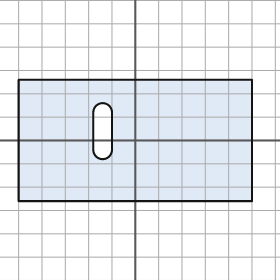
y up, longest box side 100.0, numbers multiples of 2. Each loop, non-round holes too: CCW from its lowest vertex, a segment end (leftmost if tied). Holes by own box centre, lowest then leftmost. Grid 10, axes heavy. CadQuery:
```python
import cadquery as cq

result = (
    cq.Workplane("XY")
    .moveTo(-50.0, -26.0)
    .lineTo(50.0, -26.0)
    .lineTo(50.0, 26.0)
    .lineTo(-50.0, 26.0)
    .close()
    .moveTo(-18.0, -4.0)
    .threePointArc((-14.0, -8.0), (-10.0, -4.0))
    .lineTo(-10.0, 12.0)
    .threePointArc((-14.0, 16.0), (-18.0, 12.0))
    .close()
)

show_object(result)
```